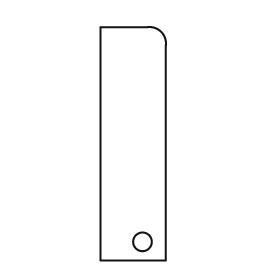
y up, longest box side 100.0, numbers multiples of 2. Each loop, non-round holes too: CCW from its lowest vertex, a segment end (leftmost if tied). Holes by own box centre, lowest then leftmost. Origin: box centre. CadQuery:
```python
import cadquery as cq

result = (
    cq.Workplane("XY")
    .moveTo(-14.0, -50.0)
    .lineTo(14.0, -50.0)
    .lineTo(14.0, 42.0)
    .threePointArc((12.0, 48.0), (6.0, 50.0))
    .lineTo(-14.0, 50.0)
    .close()
    .moveTo(4.0, -42.0)
    .circle(4.0)
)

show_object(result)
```